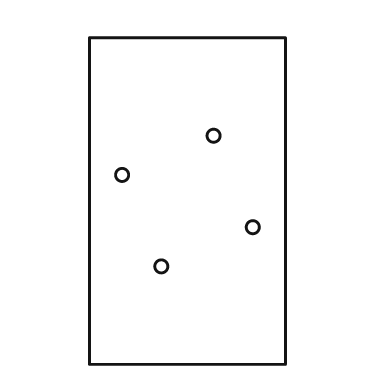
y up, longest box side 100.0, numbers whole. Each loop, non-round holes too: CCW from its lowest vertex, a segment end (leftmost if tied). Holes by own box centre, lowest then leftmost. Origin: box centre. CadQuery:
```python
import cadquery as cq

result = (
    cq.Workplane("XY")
    .moveTo(-30.0, -50.0)
    .lineTo(30.0, -50.0)
    .lineTo(30.0, 50.0)
    .lineTo(-30.0, 50.0)
    .close()
    .moveTo(-8.0, -20.0)
    .circle(2.0)
    .moveTo(20.0, -8.0)
    .circle(2.0)
    .moveTo(-20.0, 8.0)
    .circle(2.0)
    .moveTo(8.0, 20.0)
    .circle(2.0)
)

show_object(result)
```